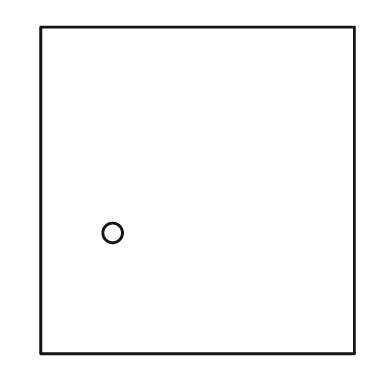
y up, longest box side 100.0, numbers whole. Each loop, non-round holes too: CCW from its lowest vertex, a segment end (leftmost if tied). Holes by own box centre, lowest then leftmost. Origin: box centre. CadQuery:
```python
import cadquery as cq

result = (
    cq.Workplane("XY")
    .moveTo(-48.0, -50.0)
    .lineTo(48.0, -50.0)
    .lineTo(48.0, 50.0)
    .lineTo(-48.0, 50.0)
    .close()
    .moveTo(-26.0, -13.0)
    .circle(3.0)
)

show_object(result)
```